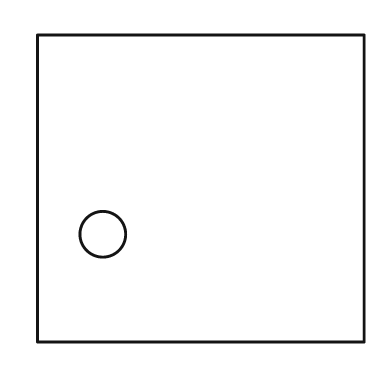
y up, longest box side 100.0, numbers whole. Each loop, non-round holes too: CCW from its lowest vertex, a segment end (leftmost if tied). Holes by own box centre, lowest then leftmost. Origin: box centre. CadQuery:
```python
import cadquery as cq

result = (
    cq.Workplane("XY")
    .moveTo(-50.0, -47.0)
    .lineTo(50.0, -47.0)
    .lineTo(50.0, 47.0)
    .lineTo(-50.0, 47.0)
    .close()
    .moveTo(-30.0, -14.0)
    .circle(7.0)
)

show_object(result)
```